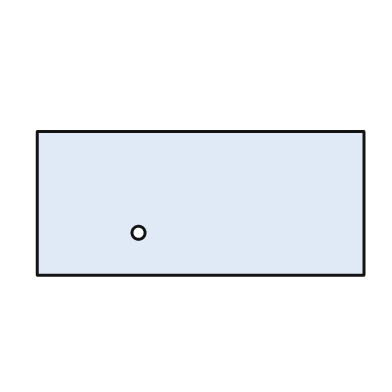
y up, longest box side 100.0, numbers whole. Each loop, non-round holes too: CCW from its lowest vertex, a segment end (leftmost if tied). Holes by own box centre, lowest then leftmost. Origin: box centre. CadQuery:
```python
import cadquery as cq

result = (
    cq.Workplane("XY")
    .moveTo(-50.0, -22.0)
    .lineTo(50.0, -22.0)
    .lineTo(50.0, 22.0)
    .lineTo(-50.0, 22.0)
    .close()
    .moveTo(-19.0, -9.0)
    .circle(2.0)
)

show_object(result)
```